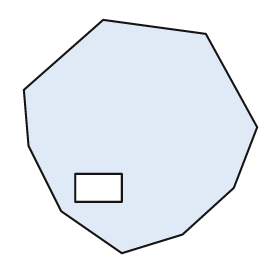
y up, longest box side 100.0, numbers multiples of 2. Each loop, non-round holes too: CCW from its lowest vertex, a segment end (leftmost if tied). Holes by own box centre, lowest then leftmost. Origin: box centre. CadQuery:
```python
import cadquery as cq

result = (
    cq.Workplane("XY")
    .moveTo(-8.0, -50.0)
    .lineTo(18.0, -42.0)
    .lineTo(40.0, -22.0)
    .lineTo(50.0, 4.0)
    .lineTo(28.0, 44.0)
    .lineTo(-16.0, 50.0)
    .lineTo(-50.0, 20.0)
    .lineTo(-48.0, -4.0)
    .lineTo(-34.0, -32.0)
    .close()
    .moveTo(-28.0, -28.0)
    .lineTo(-8.0, -28.0)
    .lineTo(-8.0, -16.0)
    .lineTo(-28.0, -16.0)
    .close()
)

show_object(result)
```